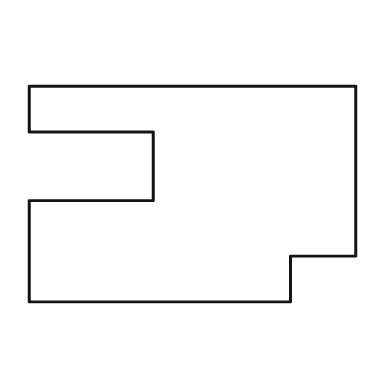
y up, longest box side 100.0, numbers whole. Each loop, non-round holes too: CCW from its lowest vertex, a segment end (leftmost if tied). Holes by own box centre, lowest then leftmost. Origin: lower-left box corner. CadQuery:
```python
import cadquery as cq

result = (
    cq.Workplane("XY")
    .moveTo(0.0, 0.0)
    .lineTo(80.0, 0.0)
    .lineTo(80.0, 14.0)
    .lineTo(100.0, 14.0)
    .lineTo(100.0, 66.0)
    .lineTo(0.0, 66.0)
    .lineTo(0.0, 52.0)
    .lineTo(38.0, 52.0)
    .lineTo(38.0, 31.0)
    .lineTo(0.0, 31.0)
    .close()
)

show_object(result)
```